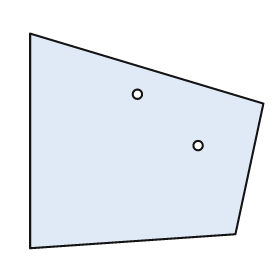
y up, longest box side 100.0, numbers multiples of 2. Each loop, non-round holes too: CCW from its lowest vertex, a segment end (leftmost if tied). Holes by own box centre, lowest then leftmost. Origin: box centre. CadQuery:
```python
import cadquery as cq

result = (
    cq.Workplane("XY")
    .moveTo(-50.0, -46.0)
    .lineTo(38.0, -40.0)
    .lineTo(50.0, 16.0)
    .lineTo(-50.0, 46.0)
    .close()
    .moveTo(22.0, -2.0)
    .circle(2.0)
    .moveTo(-4.0, 20.0)
    .circle(2.0)
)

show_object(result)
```